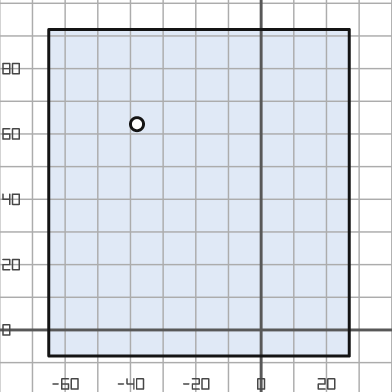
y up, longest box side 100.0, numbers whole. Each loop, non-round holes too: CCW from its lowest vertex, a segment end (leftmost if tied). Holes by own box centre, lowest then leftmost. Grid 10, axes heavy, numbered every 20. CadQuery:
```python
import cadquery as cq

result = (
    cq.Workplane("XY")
    .moveTo(-65.0, -8.0)
    .lineTo(27.0, -8.0)
    .lineTo(27.0, 92.0)
    .lineTo(-65.0, 92.0)
    .close()
    .moveTo(-38.0, 63.0)
    .circle(2.0)
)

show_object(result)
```